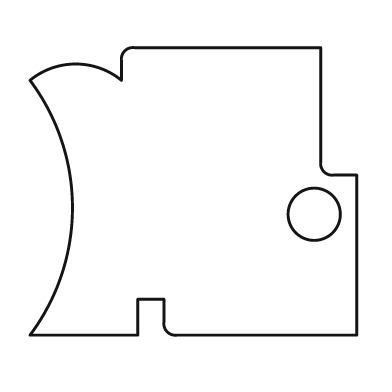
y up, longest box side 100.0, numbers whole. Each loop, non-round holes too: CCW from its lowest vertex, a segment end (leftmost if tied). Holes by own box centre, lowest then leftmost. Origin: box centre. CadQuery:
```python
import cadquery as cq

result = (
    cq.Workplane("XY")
    .moveTo(-50.0, -44.0)
    .lineTo(-17.0, -44.0)
    .lineTo(-17.0, -33.0)
    .lineTo(-9.0, -33.0)
    .lineTo(-9.0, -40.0)
    .threePointArc((-8.0, -43.0), (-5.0, -44.0))
    .lineTo(50.0, -44.0)
    .lineTo(50.0, 5.0)
    .lineTo(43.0, 5.0)
    .threePointArc((40.0, 6.0), (39.0, 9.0))
    .lineTo(39.0, 44.0)
    .lineTo(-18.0, 44.0)
    .threePointArc((-21.0, 43.0), (-22.0, 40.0))
    .lineTo(-22.0, 34.0)
    .threePointArc((-36.0, 39.0), (-50.0, 34.0))
    .threePointArc((-37.0, -5.0), (-50.0, -44.0))
    .close()
    .moveTo(37.0, -7.0)
    .circle(8.0)
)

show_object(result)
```